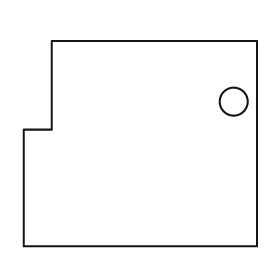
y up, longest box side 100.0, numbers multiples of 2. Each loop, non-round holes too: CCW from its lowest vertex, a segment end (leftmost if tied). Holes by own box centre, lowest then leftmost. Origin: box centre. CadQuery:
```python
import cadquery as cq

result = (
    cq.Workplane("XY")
    .moveTo(-50.0, -44.0)
    .lineTo(50.0, -44.0)
    .lineTo(50.0, 44.0)
    .lineTo(-38.0, 44.0)
    .lineTo(-38.0, 6.0)
    .lineTo(-50.0, 6.0)
    .close()
    .moveTo(40.0, 18.0)
    .circle(6.0)
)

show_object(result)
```